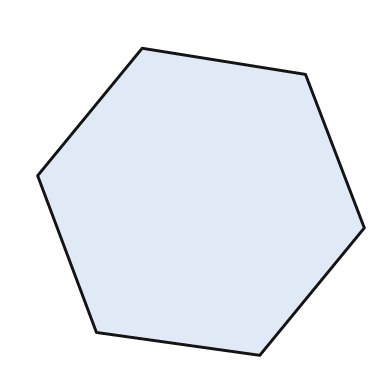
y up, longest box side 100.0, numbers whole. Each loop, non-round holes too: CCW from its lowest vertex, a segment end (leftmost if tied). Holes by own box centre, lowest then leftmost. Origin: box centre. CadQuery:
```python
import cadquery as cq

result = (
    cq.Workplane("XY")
    .moveTo(18.0, -47.0)
    .lineTo(50.0, -8.0)
    .lineTo(32.0, 39.0)
    .lineTo(-18.0, 47.0)
    .lineTo(-50.0, 8.0)
    .lineTo(-32.0, -40.0)
    .close()
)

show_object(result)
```